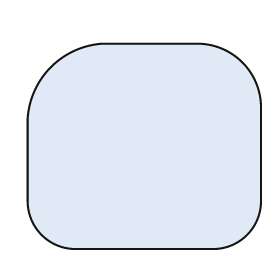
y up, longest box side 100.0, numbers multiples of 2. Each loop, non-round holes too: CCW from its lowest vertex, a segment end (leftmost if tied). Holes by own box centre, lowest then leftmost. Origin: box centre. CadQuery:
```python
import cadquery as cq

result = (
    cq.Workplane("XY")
    .moveTo(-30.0, -44.0)
    .lineTo(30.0, -44.0)
    .threePointArc((44.0, -38.0), (50.0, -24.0))
    .lineTo(50.0, 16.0)
    .threePointArc((42.0, 36.0), (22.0, 44.0))
    .lineTo(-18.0, 44.0)
    .threePointArc((-40.0, 34.0), (-50.0, 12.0))
    .lineTo(-50.0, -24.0)
    .threePointArc((-44.0, -38.0), (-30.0, -44.0))
    .close()
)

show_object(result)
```